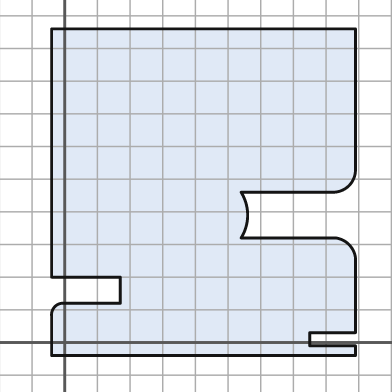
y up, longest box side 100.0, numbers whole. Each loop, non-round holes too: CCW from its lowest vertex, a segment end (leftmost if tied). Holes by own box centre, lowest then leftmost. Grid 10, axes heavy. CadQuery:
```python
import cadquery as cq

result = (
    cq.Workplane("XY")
    .moveTo(-4.0, -4.0)
    .lineTo(89.0, -4.0)
    .lineTo(89.0, -1.0)
    .lineTo(75.0, -1.0)
    .lineTo(75.0, 3.0)
    .lineTo(89.0, 3.0)
    .lineTo(89.0, 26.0)
    .threePointArc((87.0, 30.0), (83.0, 32.0))
    .lineTo(54.0, 32.0)
    .threePointArc((56.0, 39.0), (54.0, 46.0))
    .lineTo(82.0, 46.0)
    .threePointArc((87.0, 48.0), (89.0, 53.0))
    .lineTo(89.0, 96.0)
    .lineTo(-4.0, 96.0)
    .lineTo(-4.0, 20.0)
    .lineTo(17.0, 20.0)
    .lineTo(17.0, 12.0)
    .lineTo(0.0, 12.0)
    .threePointArc((-3.0, 11.0), (-4.0, 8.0))
    .close()
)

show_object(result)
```